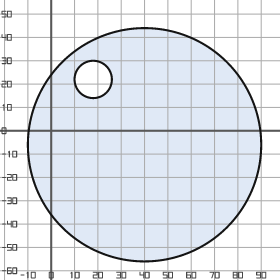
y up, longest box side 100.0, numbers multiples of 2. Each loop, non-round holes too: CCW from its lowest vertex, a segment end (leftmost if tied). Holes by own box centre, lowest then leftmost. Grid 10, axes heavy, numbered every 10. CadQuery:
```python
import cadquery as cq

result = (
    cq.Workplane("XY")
    .moveTo(40.0, -6.0)
    .circle(50.0)
    .moveTo(18.0, 22.0)
    .circle(8.0)
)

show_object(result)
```